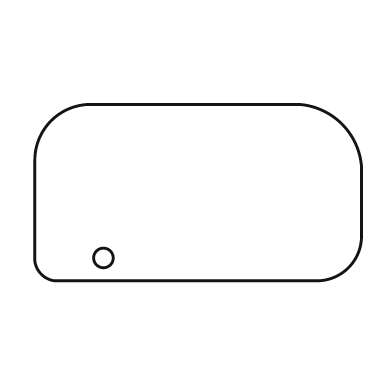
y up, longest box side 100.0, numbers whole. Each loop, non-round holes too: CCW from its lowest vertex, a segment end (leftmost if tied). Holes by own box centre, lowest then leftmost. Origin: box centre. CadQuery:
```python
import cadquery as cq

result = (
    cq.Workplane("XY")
    .moveTo(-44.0, -27.0)
    .lineTo(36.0, -27.0)
    .threePointArc((46.0, -23.0), (50.0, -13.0))
    .lineTo(50.0, 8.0)
    .threePointArc((44.0, 21.0), (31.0, 27.0))
    .lineTo(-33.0, 27.0)
    .threePointArc((-45.0, 22.0), (-50.0, 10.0))
    .lineTo(-50.0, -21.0)
    .threePointArc((-48.0, -25.0), (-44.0, -27.0))
    .close()
    .moveTo(-29.0, -20.0)
    .circle(3.0)
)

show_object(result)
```